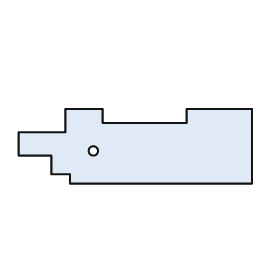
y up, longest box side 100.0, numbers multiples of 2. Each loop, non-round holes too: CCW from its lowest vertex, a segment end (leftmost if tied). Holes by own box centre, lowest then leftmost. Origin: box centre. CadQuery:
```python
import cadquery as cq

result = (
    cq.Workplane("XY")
    .moveTo(-28.0, -16.0)
    .lineTo(50.0, -16.0)
    .lineTo(50.0, 16.0)
    .lineTo(22.0, 16.0)
    .lineTo(22.0, 10.0)
    .lineTo(-14.0, 10.0)
    .lineTo(-14.0, 16.0)
    .lineTo(-30.0, 16.0)
    .lineTo(-30.0, 6.0)
    .lineTo(-50.0, 6.0)
    .lineTo(-50.0, -4.0)
    .lineTo(-36.0, -4.0)
    .lineTo(-36.0, -12.0)
    .lineTo(-28.0, -12.0)
    .close()
    .moveTo(-18.0, -2.0)
    .circle(2.0)
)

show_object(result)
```